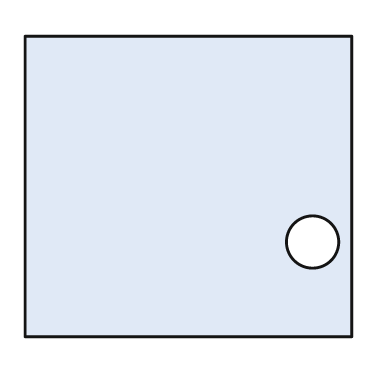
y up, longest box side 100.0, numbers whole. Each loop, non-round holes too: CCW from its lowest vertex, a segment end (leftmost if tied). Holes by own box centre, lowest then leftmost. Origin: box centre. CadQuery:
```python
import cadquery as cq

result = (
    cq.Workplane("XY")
    .moveTo(-50.0, -46.0)
    .lineTo(50.0, -46.0)
    .lineTo(50.0, 46.0)
    .lineTo(-50.0, 46.0)
    .close()
    .moveTo(38.0, -17.0)
    .circle(8.0)
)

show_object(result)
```